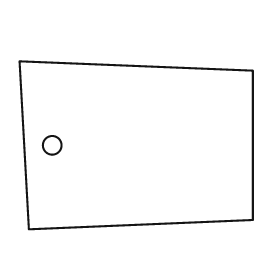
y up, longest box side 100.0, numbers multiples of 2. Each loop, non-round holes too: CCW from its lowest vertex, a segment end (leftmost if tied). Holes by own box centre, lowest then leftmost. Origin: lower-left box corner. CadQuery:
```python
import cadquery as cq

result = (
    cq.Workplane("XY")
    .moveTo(4.0, 0.0)
    .lineTo(100.0, 4.0)
    .lineTo(100.0, 68.0)
    .lineTo(0.0, 72.0)
    .close()
    .moveTo(14.0, 36.0)
    .circle(4.0)
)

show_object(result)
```